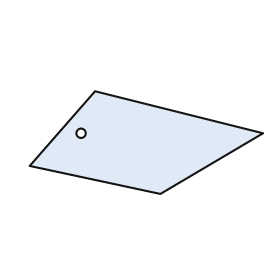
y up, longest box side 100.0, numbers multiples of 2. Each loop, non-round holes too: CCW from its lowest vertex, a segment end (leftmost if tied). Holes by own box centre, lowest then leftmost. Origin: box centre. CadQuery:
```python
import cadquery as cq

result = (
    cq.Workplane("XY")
    .moveTo(6.0, -22.0)
    .lineTo(50.0, 4.0)
    .lineTo(-22.0, 22.0)
    .lineTo(-50.0, -10.0)
    .close()
    .moveTo(-28.0, 4.0)
    .circle(2.0)
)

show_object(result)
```